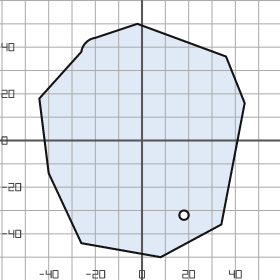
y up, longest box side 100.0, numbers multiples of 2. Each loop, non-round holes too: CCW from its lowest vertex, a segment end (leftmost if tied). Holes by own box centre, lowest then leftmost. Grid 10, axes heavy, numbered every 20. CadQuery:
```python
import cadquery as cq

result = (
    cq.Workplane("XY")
    .moveTo(8.0, -50.0)
    .lineTo(34.0, -36.0)
    .lineTo(44.0, 16.0)
    .lineTo(36.0, 36.0)
    .lineTo(-2.0, 50.0)
    .lineTo(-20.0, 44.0)
    .threePointArc((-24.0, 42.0), (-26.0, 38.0))
    .lineTo(-44.0, 18.0)
    .lineTo(-40.0, -14.0)
    .lineTo(-26.0, -44.0)
    .close()
    .moveTo(18.0, -32.0)
    .circle(2.0)
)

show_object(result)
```